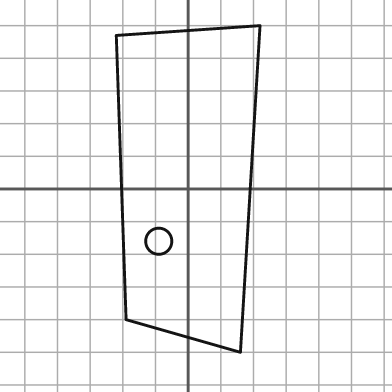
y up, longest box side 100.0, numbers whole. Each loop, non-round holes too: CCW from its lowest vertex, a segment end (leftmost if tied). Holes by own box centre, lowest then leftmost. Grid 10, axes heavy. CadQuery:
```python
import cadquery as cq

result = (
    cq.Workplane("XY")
    .moveTo(16.0, -50.0)
    .lineTo(22.0, 50.0)
    .lineTo(-22.0, 47.0)
    .lineTo(-19.0, -40.0)
    .close()
    .moveTo(-9.0, -16.0)
    .circle(4.0)
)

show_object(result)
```